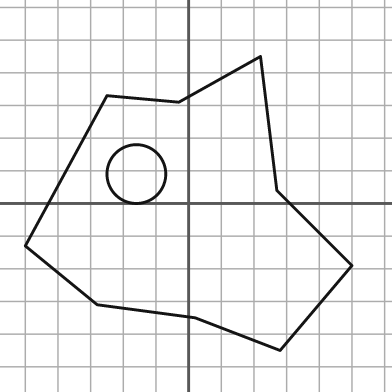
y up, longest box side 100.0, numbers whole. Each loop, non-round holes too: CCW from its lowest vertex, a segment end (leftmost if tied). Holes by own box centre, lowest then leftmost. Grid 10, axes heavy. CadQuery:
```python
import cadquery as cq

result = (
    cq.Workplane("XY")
    .moveTo(28.0, -45.0)
    .lineTo(50.0, -19.0)
    .lineTo(27.0, 4.0)
    .lineTo(22.0, 45.0)
    .lineTo(-3.0, 31.0)
    .lineTo(-25.0, 33.0)
    .lineTo(-50.0, -13.0)
    .lineTo(-28.0, -31.0)
    .lineTo(2.0, -35.0)
    .close()
    .moveTo(-16.0, 9.0)
    .circle(9.0)
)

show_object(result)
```